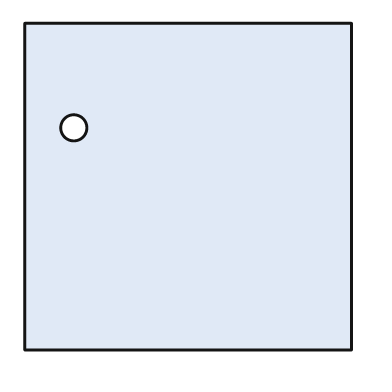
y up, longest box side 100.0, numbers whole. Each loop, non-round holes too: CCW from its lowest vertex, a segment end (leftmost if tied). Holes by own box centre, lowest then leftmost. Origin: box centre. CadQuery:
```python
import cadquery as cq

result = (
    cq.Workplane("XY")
    .moveTo(-50.0, -50.0)
    .lineTo(50.0, -50.0)
    .lineTo(50.0, 50.0)
    .lineTo(-50.0, 50.0)
    .close()
    .moveTo(-35.0, 18.0)
    .circle(4.0)
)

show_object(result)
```